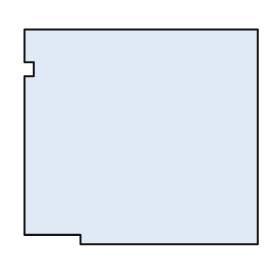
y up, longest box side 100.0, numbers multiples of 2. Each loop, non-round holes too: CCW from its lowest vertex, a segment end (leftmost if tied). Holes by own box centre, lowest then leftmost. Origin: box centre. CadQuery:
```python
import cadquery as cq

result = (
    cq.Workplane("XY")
    .moveTo(-26.0, -46.0)
    .lineTo(50.0, -46.0)
    .lineTo(50.0, 46.0)
    .lineTo(-50.0, 46.0)
    .lineTo(-50.0, 32.0)
    .lineTo(-46.0, 32.0)
    .lineTo(-46.0, 26.0)
    .lineTo(-50.0, 26.0)
    .lineTo(-50.0, -42.0)
    .lineTo(-26.0, -42.0)
    .close()
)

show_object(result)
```